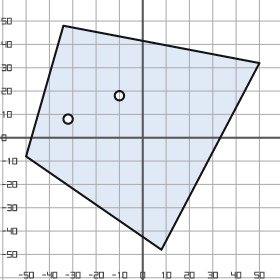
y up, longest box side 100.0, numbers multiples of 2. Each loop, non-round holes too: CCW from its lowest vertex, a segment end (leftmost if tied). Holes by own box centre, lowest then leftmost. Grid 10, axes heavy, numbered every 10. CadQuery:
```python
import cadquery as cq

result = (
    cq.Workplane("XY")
    .moveTo(8.0, -48.0)
    .lineTo(50.0, 32.0)
    .lineTo(-34.0, 48.0)
    .lineTo(-50.0, -8.0)
    .close()
    .moveTo(-32.0, 8.0)
    .circle(2.0)
    .moveTo(-10.0, 18.0)
    .circle(2.0)
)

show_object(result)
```